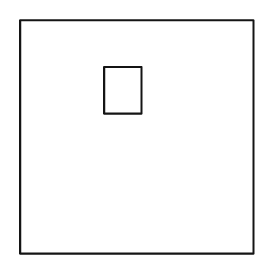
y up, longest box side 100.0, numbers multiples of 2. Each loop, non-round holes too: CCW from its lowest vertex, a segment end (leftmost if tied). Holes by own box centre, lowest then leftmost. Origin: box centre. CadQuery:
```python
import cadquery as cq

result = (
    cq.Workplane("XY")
    .moveTo(-50.0, -50.0)
    .lineTo(50.0, -50.0)
    .lineTo(50.0, 50.0)
    .lineTo(-50.0, 50.0)
    .close()
    .moveTo(-14.0, 10.0)
    .lineTo(2.0, 10.0)
    .lineTo(2.0, 30.0)
    .lineTo(-14.0, 30.0)
    .close()
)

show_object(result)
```